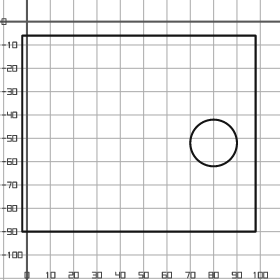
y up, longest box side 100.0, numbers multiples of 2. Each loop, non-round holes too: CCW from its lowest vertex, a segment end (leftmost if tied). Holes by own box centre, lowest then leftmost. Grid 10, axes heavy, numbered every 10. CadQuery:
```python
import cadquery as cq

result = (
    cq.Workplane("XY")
    .moveTo(-2.0, -90.0)
    .lineTo(98.0, -90.0)
    .lineTo(98.0, -6.0)
    .lineTo(-2.0, -6.0)
    .close()
    .moveTo(80.0, -52.0)
    .circle(10.0)
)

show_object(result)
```